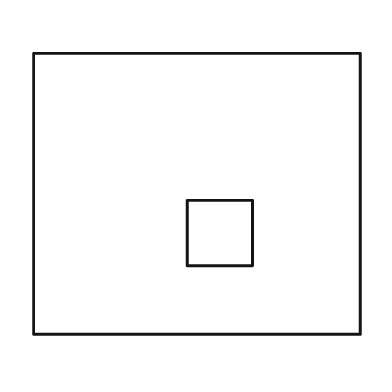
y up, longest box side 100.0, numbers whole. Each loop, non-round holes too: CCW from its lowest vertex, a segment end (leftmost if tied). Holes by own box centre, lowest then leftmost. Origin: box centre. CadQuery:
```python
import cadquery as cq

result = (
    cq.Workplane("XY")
    .moveTo(-50.0, -43.0)
    .lineTo(50.0, -43.0)
    .lineTo(50.0, 43.0)
    .lineTo(-50.0, 43.0)
    .close()
    .moveTo(-3.0, -22.0)
    .lineTo(17.0, -22.0)
    .lineTo(17.0, -2.0)
    .lineTo(-3.0, -2.0)
    .close()
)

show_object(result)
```